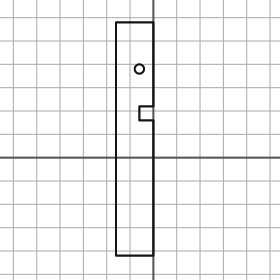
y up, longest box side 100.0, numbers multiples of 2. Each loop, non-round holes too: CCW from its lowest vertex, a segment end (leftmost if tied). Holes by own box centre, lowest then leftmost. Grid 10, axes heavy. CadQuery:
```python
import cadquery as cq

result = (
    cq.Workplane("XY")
    .moveTo(-16.0, -42.0)
    .lineTo(0.0, -42.0)
    .lineTo(0.0, 16.0)
    .lineTo(-6.0, 16.0)
    .lineTo(-6.0, 22.0)
    .lineTo(0.0, 22.0)
    .lineTo(0.0, 58.0)
    .lineTo(-16.0, 58.0)
    .close()
    .moveTo(-6.0, 38.0)
    .circle(2.0)
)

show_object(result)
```